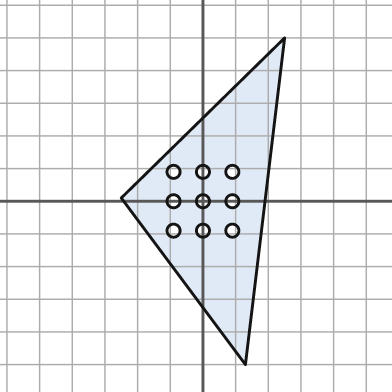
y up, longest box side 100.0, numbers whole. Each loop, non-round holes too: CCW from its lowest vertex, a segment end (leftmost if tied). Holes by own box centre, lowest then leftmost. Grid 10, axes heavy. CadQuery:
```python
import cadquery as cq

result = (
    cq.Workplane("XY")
    .moveTo(13.0, -50.0)
    .lineTo(25.0, 50.0)
    .lineTo(-25.0, 1.0)
    .close()
    .moveTo(-9.0, -9.0)
    .circle(2.0)
    .moveTo(0.0, -9.0)
    .circle(2.0)
    .moveTo(9.0, -9.0)
    .circle(2.0)
    .moveTo(-9.0, 0.0)
    .circle(2.0)
    .moveTo(0.0, 0.0)
    .circle(2.0)
    .moveTo(9.0, 0.0)
    .circle(2.0)
    .moveTo(-9.0, 9.0)
    .circle(2.0)
    .moveTo(0.0, 9.0)
    .circle(2.0)
    .moveTo(9.0, 9.0)
    .circle(2.0)
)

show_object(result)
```